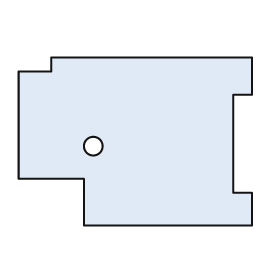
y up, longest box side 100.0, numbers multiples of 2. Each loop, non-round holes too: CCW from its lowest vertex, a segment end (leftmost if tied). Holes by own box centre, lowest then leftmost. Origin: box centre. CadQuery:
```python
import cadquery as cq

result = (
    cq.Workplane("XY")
    .moveTo(-22.0, -36.0)
    .lineTo(50.0, -36.0)
    .lineTo(50.0, -22.0)
    .lineTo(42.0, -22.0)
    .lineTo(42.0, 20.0)
    .lineTo(50.0, 20.0)
    .lineTo(50.0, 36.0)
    .lineTo(-36.0, 36.0)
    .lineTo(-36.0, 30.0)
    .lineTo(-50.0, 30.0)
    .lineTo(-50.0, -16.0)
    .lineTo(-22.0, -16.0)
    .close()
    .moveTo(-18.0, -2.0)
    .circle(4.0)
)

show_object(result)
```